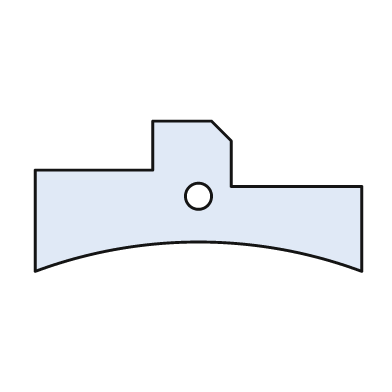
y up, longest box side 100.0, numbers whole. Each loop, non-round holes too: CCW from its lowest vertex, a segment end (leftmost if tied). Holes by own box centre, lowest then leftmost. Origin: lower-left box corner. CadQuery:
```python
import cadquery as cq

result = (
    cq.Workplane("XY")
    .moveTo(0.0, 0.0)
    .threePointArc((50.0, 9.0), (100.0, 0.0))
    .lineTo(100.0, 26.0)
    .lineTo(60.0, 26.0)
    .lineTo(60.0, 40.0)
    .lineTo(54.0, 46.0)
    .lineTo(36.0, 46.0)
    .lineTo(36.0, 31.0)
    .lineTo(0.0, 31.0)
    .close()
    .moveTo(50.0, 23.0)
    .circle(4.0)
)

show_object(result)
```